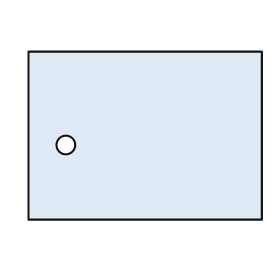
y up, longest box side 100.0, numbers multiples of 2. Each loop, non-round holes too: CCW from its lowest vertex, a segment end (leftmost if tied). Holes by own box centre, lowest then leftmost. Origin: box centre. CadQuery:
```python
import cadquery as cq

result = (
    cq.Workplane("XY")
    .moveTo(-50.0, -36.0)
    .lineTo(50.0, -36.0)
    .lineTo(50.0, 36.0)
    .lineTo(-50.0, 36.0)
    .close()
    .moveTo(-34.0, -4.0)
    .circle(4.0)
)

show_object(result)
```